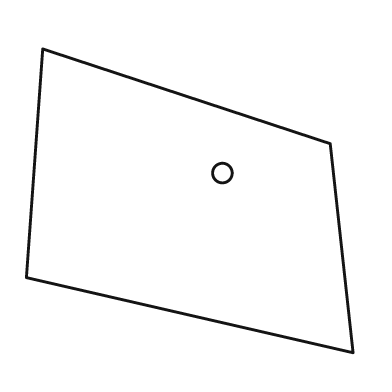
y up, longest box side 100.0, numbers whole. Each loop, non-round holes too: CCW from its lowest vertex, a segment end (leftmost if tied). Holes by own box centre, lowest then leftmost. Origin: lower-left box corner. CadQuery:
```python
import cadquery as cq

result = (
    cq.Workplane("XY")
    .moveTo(100.0, 0.0)
    .lineTo(93.0, 64.0)
    .lineTo(5.0, 93.0)
    .lineTo(0.0, 23.0)
    .close()
    .moveTo(60.0, 55.0)
    .circle(3.0)
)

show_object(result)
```